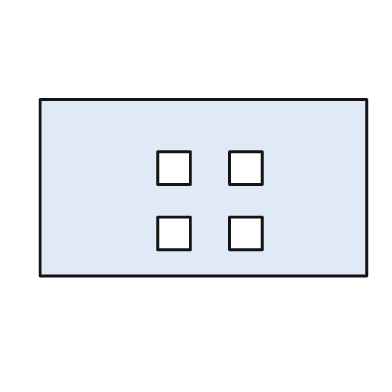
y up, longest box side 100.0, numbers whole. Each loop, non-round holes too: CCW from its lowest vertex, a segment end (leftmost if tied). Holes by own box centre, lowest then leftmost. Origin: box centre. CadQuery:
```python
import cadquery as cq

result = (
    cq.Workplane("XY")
    .moveTo(-50.0, -27.0)
    .lineTo(50.0, -27.0)
    .lineTo(50.0, 27.0)
    .lineTo(-50.0, 27.0)
    .close()
    .moveTo(-14.0, -19.0)
    .lineTo(-4.0, -19.0)
    .lineTo(-4.0, -9.0)
    .lineTo(-14.0, -9.0)
    .close()
    .moveTo(8.0, -19.0)
    .lineTo(18.0, -19.0)
    .lineTo(18.0, -9.0)
    .lineTo(8.0, -9.0)
    .close()
    .moveTo(-14.0, 1.0)
    .lineTo(-4.0, 1.0)
    .lineTo(-4.0, 11.0)
    .lineTo(-14.0, 11.0)
    .close()
    .moveTo(8.0, 1.0)
    .lineTo(18.0, 1.0)
    .lineTo(18.0, 11.0)
    .lineTo(8.0, 11.0)
    .close()
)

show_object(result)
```